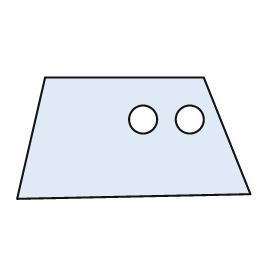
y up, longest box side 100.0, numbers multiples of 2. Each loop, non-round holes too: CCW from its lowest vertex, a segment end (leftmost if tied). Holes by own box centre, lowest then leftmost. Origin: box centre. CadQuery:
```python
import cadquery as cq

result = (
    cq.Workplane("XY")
    .moveTo(-50.0, -26.0)
    .lineTo(50.0, -24.0)
    .lineTo(30.0, 26.0)
    .lineTo(-38.0, 26.0)
    .close()
    .moveTo(4.0, 8.0)
    .circle(6.0)
    .moveTo(24.0, 8.0)
    .circle(6.0)
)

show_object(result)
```